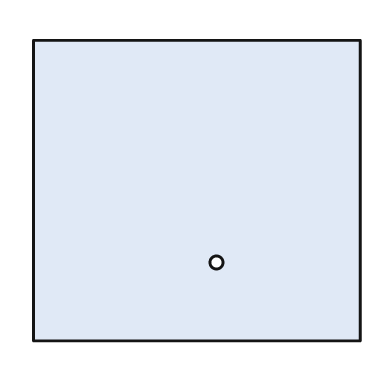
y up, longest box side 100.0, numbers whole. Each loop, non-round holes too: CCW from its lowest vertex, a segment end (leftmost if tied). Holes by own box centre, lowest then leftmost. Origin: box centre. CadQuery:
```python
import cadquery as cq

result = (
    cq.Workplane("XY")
    .moveTo(-50.0, -46.0)
    .lineTo(50.0, -46.0)
    .lineTo(50.0, 46.0)
    .lineTo(-50.0, 46.0)
    .close()
    .moveTo(6.0, -22.0)
    .circle(2.0)
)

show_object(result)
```